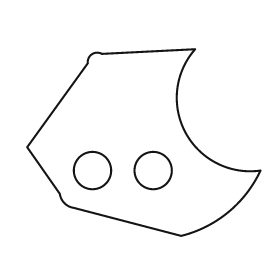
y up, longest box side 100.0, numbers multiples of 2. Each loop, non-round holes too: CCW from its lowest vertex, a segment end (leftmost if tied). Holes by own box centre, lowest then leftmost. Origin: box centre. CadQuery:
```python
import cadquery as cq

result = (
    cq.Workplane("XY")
    .moveTo(16.0, -40.0)
    .threePointArc((36.0, -30.0), (50.0, -12.0))
    .threePointArc((18.0, 4.0), (22.0, 40.0))
    .lineTo(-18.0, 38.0)
    .threePointArc((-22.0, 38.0), (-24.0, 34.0))
    .lineTo(-50.0, -2.0)
    .lineTo(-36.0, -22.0)
    .threePointArc((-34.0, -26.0), (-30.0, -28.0))
    .close()
    .moveTo(-22.0, -12.0)
    .circle(8.0)
    .moveTo(4.0, -12.0)
    .circle(8.0)
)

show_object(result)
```